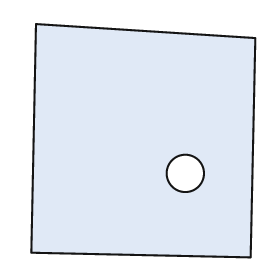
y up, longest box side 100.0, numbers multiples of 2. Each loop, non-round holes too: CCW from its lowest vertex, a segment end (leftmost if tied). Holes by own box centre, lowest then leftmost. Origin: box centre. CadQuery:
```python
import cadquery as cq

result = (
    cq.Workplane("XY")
    .moveTo(46.0, -50.0)
    .lineTo(48.0, 44.0)
    .lineTo(-46.0, 50.0)
    .lineTo(-48.0, -48.0)
    .close()
    .moveTo(18.0, -14.0)
    .circle(8.0)
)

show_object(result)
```